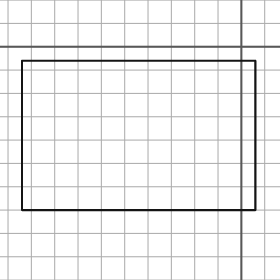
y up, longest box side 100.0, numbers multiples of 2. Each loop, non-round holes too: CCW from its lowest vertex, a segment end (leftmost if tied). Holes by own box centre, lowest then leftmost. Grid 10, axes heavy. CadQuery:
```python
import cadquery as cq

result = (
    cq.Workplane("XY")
    .moveTo(-94.0, -70.0)
    .lineTo(6.0, -70.0)
    .lineTo(6.0, -6.0)
    .lineTo(-94.0, -6.0)
    .close()
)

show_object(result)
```